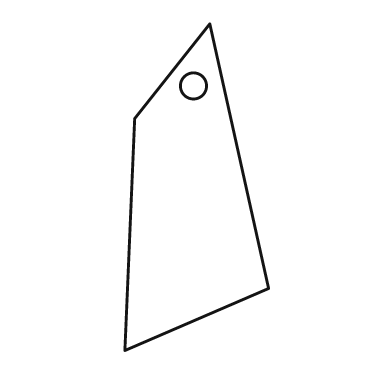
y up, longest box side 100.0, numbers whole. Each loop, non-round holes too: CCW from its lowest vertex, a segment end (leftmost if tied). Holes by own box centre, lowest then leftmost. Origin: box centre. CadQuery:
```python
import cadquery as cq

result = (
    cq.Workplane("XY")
    .moveTo(-22.0, -50.0)
    .lineTo(22.0, -31.0)
    .lineTo(4.0, 50.0)
    .lineTo(-19.0, 21.0)
    .close()
    .moveTo(-1.0, 31.0)
    .circle(4.0)
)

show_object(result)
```